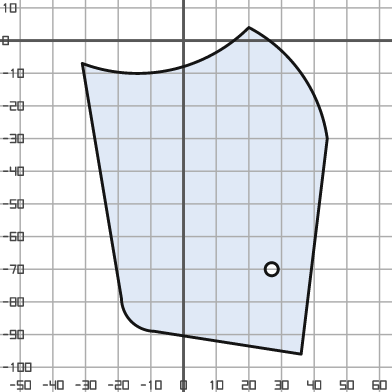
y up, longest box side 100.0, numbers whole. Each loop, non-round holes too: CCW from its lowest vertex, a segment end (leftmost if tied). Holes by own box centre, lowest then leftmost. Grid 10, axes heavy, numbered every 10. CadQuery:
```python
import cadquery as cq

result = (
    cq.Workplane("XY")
    .moveTo(36.0, -96.0)
    .lineTo(44.0, -30.0)
    .threePointArc((36.0, -10.0), (20.0, 4.0))
    .threePointArc((-4.0, -9.0), (-31.0, -7.0))
    .lineTo(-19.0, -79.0)
    .threePointArc((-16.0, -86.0), (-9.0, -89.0))
    .close()
    .moveTo(27.0, -70.0)
    .circle(2.0)
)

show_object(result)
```